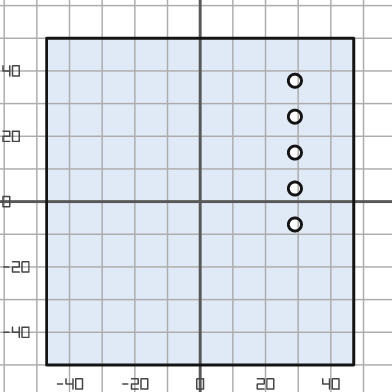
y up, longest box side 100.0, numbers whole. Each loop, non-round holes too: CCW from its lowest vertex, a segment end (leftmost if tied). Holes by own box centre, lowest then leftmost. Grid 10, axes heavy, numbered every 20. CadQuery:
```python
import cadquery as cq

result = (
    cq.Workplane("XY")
    .moveTo(-47.0, -50.0)
    .lineTo(47.0, -50.0)
    .lineTo(47.0, 50.0)
    .lineTo(-47.0, 50.0)
    .close()
    .moveTo(29.0, -7.0)
    .circle(2.0)
    .moveTo(29.0, 4.0)
    .circle(2.0)
    .moveTo(29.0, 15.0)
    .circle(2.0)
    .moveTo(29.0, 26.0)
    .circle(2.0)
    .moveTo(29.0, 37.0)
    .circle(2.0)
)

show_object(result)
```